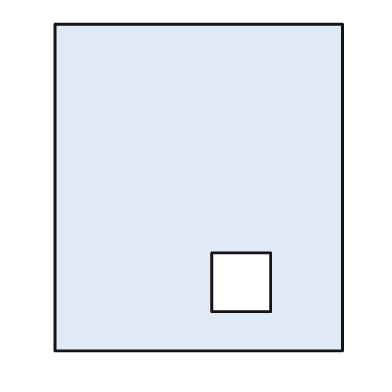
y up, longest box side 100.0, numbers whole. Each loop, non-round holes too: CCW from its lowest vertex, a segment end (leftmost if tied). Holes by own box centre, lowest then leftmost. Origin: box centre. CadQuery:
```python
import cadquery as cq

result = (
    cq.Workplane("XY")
    .moveTo(-44.0, -50.0)
    .lineTo(44.0, -50.0)
    .lineTo(44.0, 50.0)
    .lineTo(-44.0, 50.0)
    .close()
    .moveTo(4.0, -38.0)
    .lineTo(22.0, -38.0)
    .lineTo(22.0, -20.0)
    .lineTo(4.0, -20.0)
    .close()
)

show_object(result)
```